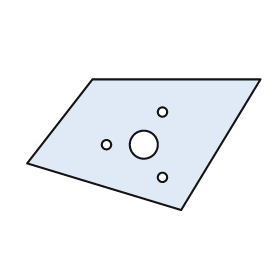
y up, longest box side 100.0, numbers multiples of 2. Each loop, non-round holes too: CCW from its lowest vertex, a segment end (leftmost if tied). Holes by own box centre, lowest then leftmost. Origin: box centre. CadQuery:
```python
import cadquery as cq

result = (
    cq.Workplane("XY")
    .moveTo(16.0, -28.0)
    .lineTo(50.0, 28.0)
    .lineTo(-22.0, 28.0)
    .lineTo(-50.0, -8.0)
    .close()
    .moveTo(8.0, -14.0)
    .circle(2.0)
    .moveTo(-16.0, 0.0)
    .circle(2.0)
    .moveTo(0.0, 0.0)
    .circle(6.0)
    .moveTo(8.0, 14.0)
    .circle(2.0)
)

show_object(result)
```